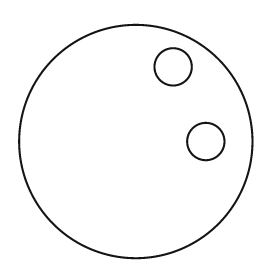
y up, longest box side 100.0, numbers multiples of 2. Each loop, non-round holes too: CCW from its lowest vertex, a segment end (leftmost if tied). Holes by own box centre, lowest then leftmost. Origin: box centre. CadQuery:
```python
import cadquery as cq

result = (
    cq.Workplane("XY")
    .moveTo(0.0, 0.0)
    .circle(50.0)
    .moveTo(30.0, 0.0)
    .circle(8.0)
    .moveTo(16.0, 32.0)
    .circle(8.0)
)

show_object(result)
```